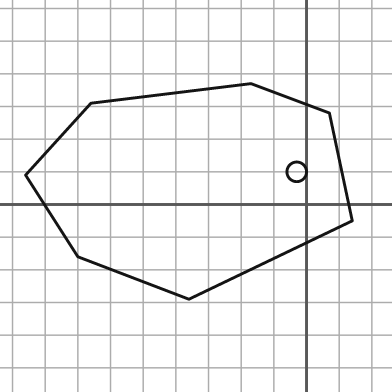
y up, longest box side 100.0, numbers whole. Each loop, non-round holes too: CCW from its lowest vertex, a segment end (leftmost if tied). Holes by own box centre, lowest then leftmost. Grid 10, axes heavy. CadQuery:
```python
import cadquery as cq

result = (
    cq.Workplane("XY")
    .moveTo(-36.0, -29.0)
    .lineTo(14.0, -5.0)
    .lineTo(7.0, 28.0)
    .lineTo(-17.0, 37.0)
    .lineTo(-66.0, 31.0)
    .lineTo(-86.0, 9.0)
    .lineTo(-70.0, -16.0)
    .close()
    .moveTo(-3.0, 10.0)
    .circle(3.0)
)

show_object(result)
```